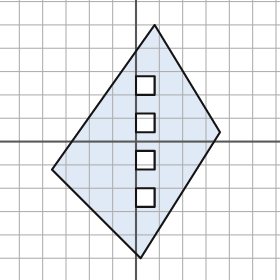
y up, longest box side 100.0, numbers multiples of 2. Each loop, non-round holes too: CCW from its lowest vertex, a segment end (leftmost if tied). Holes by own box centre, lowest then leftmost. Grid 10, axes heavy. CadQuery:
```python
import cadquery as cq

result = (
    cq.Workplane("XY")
    .moveTo(2.0, -50.0)
    .lineTo(36.0, 4.0)
    .lineTo(8.0, 50.0)
    .lineTo(-36.0, -12.0)
    .close()
    .moveTo(0.0, -28.0)
    .lineTo(8.0, -28.0)
    .lineTo(8.0, -20.0)
    .lineTo(0.0, -20.0)
    .close()
    .moveTo(0.0, -12.0)
    .lineTo(8.0, -12.0)
    .lineTo(8.0, -4.0)
    .lineTo(0.0, -4.0)
    .close()
    .moveTo(0.0, 4.0)
    .lineTo(8.0, 4.0)
    .lineTo(8.0, 12.0)
    .lineTo(0.0, 12.0)
    .close()
    .moveTo(0.0, 20.0)
    .lineTo(8.0, 20.0)
    .lineTo(8.0, 28.0)
    .lineTo(0.0, 28.0)
    .close()
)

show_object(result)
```